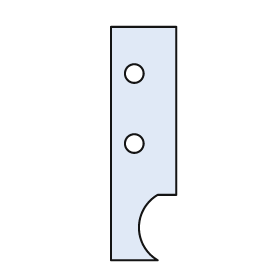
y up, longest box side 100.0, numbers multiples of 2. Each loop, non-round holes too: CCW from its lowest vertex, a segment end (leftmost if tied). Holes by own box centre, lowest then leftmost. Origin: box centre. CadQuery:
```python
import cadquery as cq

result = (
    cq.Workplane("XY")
    .moveTo(-14.0, -50.0)
    .lineTo(6.0, -50.0)
    .threePointArc((-2.0, -36.0), (6.0, -22.0))
    .lineTo(14.0, -22.0)
    .lineTo(14.0, 50.0)
    .lineTo(-14.0, 50.0)
    .close()
    .moveTo(-4.0, 0.0)
    .circle(4.0)
    .moveTo(-4.0, 30.0)
    .circle(4.0)
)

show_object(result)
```